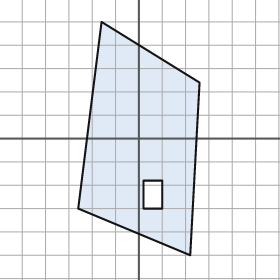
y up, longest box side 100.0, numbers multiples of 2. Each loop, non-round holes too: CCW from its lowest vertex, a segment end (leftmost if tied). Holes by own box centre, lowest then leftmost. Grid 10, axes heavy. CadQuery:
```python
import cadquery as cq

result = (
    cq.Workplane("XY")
    .moveTo(22.0, -50.0)
    .lineTo(26.0, 24.0)
    .lineTo(-16.0, 50.0)
    .lineTo(-26.0, -30.0)
    .close()
    .moveTo(2.0, -30.0)
    .lineTo(10.0, -30.0)
    .lineTo(10.0, -18.0)
    .lineTo(2.0, -18.0)
    .close()
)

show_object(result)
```